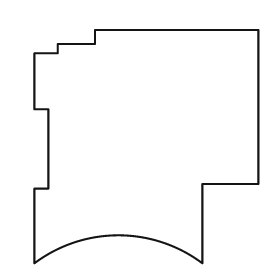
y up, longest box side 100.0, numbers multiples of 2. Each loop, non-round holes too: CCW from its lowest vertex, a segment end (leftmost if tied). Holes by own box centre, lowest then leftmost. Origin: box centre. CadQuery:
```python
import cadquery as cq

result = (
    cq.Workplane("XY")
    .moveTo(-48.0, -50.0)
    .threePointArc((-12.0, -38.0), (24.0, -50.0))
    .lineTo(24.0, -16.0)
    .lineTo(48.0, -16.0)
    .lineTo(48.0, 50.0)
    .lineTo(-22.0, 50.0)
    .lineTo(-22.0, 44.0)
    .lineTo(-38.0, 44.0)
    .lineTo(-38.0, 40.0)
    .lineTo(-48.0, 40.0)
    .lineTo(-48.0, 16.0)
    .lineTo(-42.0, 16.0)
    .lineTo(-42.0, -18.0)
    .lineTo(-48.0, -18.0)
    .close()
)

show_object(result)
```